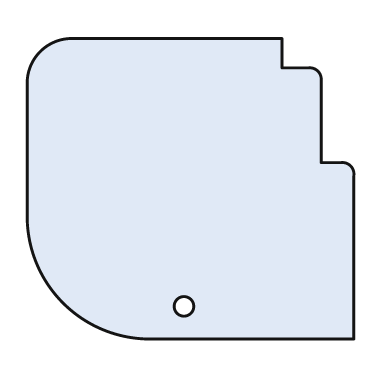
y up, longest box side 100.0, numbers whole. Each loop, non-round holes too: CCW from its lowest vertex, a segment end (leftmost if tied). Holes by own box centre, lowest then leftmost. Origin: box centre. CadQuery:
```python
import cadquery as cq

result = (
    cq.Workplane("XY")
    .moveTo(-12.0, -46.0)
    .lineTo(50.0, -46.0)
    .lineTo(50.0, 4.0)
    .threePointArc((49.0, 7.0), (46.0, 8.0))
    .lineTo(40.0, 8.0)
    .lineTo(40.0, 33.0)
    .threePointArc((39.0, 36.0), (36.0, 37.0))
    .lineTo(28.0, 37.0)
    .lineTo(28.0, 46.0)
    .lineTo(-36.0, 46.0)
    .threePointArc((-46.0, 42.0), (-50.0, 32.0))
    .lineTo(-50.0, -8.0)
    .threePointArc((-39.0, -35.0), (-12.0, -46.0))
    .close()
    .moveTo(-2.0, -36.0)
    .circle(3.0)
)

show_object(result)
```